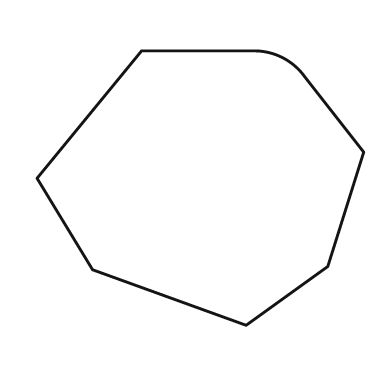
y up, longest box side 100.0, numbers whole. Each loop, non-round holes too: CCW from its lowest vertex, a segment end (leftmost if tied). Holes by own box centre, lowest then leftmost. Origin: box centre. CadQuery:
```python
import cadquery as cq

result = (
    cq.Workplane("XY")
    .moveTo(14.0, -42.0)
    .lineTo(39.0, -24.0)
    .lineTo(50.0, 11.0)
    .lineTo(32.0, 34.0)
    .threePointArc((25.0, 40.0), (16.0, 42.0))
    .lineTo(-18.0, 42.0)
    .lineTo(-50.0, 3.0)
    .lineTo(-33.0, -25.0)
    .close()
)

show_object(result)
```